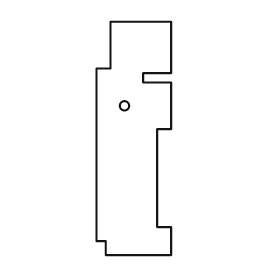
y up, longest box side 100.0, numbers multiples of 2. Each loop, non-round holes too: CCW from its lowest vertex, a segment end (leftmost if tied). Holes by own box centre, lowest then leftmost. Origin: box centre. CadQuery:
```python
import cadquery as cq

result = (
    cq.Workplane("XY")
    .moveTo(-12.0, -50.0)
    .lineTo(16.0, -50.0)
    .lineTo(16.0, -38.0)
    .lineTo(10.0, -38.0)
    .lineTo(10.0, 4.0)
    .lineTo(16.0, 4.0)
    .lineTo(16.0, 24.0)
    .lineTo(4.0, 24.0)
    .lineTo(4.0, 28.0)
    .lineTo(16.0, 28.0)
    .lineTo(16.0, 50.0)
    .lineTo(-10.0, 50.0)
    .lineTo(-10.0, 30.0)
    .lineTo(-16.0, 30.0)
    .lineTo(-16.0, -44.0)
    .lineTo(-12.0, -44.0)
    .close()
    .moveTo(-4.0, 14.0)
    .circle(2.0)
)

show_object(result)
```